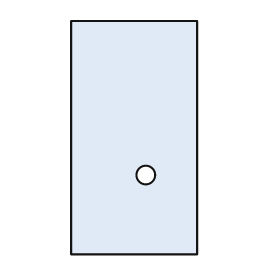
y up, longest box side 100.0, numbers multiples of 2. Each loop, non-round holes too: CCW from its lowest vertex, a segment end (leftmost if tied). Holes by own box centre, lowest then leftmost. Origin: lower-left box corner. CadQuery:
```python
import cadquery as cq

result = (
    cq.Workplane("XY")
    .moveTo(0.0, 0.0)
    .lineTo(54.0, 0.0)
    .lineTo(54.0, 100.0)
    .lineTo(0.0, 100.0)
    .close()
    .moveTo(32.0, 34.0)
    .circle(4.0)
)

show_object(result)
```